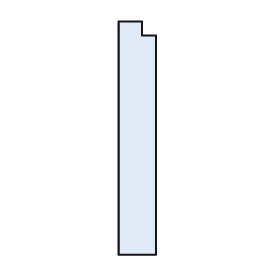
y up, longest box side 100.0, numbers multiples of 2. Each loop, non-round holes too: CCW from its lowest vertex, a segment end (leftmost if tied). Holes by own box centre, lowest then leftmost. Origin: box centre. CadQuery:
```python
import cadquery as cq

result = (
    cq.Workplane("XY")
    .moveTo(-8.0, -50.0)
    .lineTo(8.0, -50.0)
    .lineTo(8.0, 44.0)
    .lineTo(2.0, 44.0)
    .lineTo(2.0, 50.0)
    .lineTo(-8.0, 50.0)
    .close()
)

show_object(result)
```